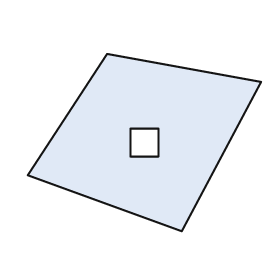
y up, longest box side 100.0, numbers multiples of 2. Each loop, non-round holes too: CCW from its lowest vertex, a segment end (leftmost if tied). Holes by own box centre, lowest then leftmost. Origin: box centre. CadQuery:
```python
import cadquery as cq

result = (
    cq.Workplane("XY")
    .moveTo(16.0, -38.0)
    .lineTo(50.0, 26.0)
    .lineTo(-16.0, 38.0)
    .lineTo(-50.0, -14.0)
    .close()
    .moveTo(-6.0, -6.0)
    .lineTo(6.0, -6.0)
    .lineTo(6.0, 6.0)
    .lineTo(-6.0, 6.0)
    .close()
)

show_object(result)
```